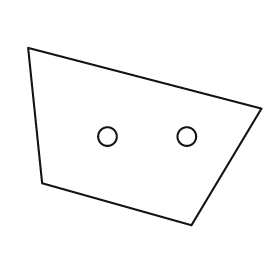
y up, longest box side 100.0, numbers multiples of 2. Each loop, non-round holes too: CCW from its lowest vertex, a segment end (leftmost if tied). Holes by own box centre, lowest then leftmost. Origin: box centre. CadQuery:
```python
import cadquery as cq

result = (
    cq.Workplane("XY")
    .moveTo(20.0, -38.0)
    .lineTo(50.0, 12.0)
    .lineTo(-50.0, 38.0)
    .lineTo(-44.0, -20.0)
    .close()
    .moveTo(-16.0, 0.0)
    .circle(4.0)
    .moveTo(18.0, 0.0)
    .circle(4.0)
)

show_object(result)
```